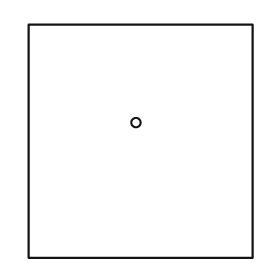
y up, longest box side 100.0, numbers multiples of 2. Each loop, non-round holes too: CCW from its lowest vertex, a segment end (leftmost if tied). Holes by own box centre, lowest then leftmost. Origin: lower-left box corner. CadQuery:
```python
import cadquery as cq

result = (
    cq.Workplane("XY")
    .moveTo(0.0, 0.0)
    .lineTo(96.0, 0.0)
    .lineTo(96.0, 100.0)
    .lineTo(0.0, 100.0)
    .close()
    .moveTo(46.0, 58.0)
    .circle(2.0)
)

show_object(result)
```